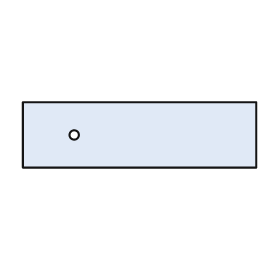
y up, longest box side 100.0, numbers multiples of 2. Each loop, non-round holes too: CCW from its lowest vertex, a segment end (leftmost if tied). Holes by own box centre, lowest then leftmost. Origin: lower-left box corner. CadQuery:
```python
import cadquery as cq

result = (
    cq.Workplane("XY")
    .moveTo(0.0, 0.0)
    .lineTo(100.0, 0.0)
    .lineTo(100.0, 28.0)
    .lineTo(0.0, 28.0)
    .close()
    .moveTo(22.0, 14.0)
    .circle(2.0)
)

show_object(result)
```